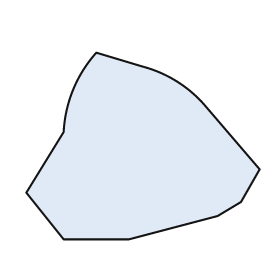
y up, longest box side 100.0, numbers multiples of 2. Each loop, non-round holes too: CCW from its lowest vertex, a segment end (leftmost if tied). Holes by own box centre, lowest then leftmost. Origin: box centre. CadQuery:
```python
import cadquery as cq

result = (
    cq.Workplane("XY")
    .moveTo(-34.0, -40.0)
    .lineTo(-6.0, -40.0)
    .lineTo(32.0, -30.0)
    .lineTo(42.0, -24.0)
    .lineTo(50.0, -10.0)
    .lineTo(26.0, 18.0)
    .threePointArc((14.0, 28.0), (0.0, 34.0))
    .lineTo(-20.0, 40.0)
    .threePointArc((-30.0, 24.0), (-34.0, 6.0))
    .lineTo(-50.0, -20.0)
    .close()
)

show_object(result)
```